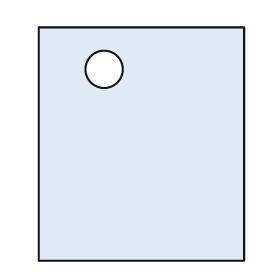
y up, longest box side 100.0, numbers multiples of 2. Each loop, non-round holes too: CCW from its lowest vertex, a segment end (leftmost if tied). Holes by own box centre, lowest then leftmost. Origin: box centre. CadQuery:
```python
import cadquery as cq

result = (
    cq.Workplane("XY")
    .moveTo(-44.0, -50.0)
    .lineTo(44.0, -50.0)
    .lineTo(44.0, 50.0)
    .lineTo(-44.0, 50.0)
    .close()
    .moveTo(-16.0, 32.0)
    .circle(8.0)
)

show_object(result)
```